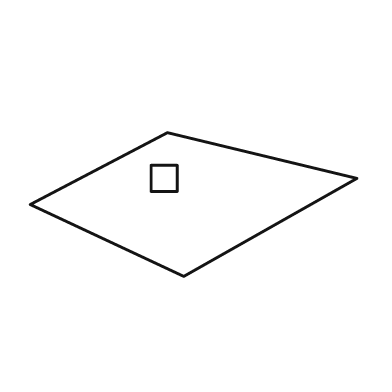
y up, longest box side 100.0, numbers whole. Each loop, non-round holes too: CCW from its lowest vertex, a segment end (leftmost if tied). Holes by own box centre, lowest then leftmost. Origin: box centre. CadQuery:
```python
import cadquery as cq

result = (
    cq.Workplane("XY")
    .moveTo(-3.0, -22.0)
    .lineTo(50.0, 8.0)
    .lineTo(-8.0, 22.0)
    .lineTo(-50.0, 0.0)
    .close()
    .moveTo(-13.0, 4.0)
    .lineTo(-5.0, 4.0)
    .lineTo(-5.0, 12.0)
    .lineTo(-13.0, 12.0)
    .close()
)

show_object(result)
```